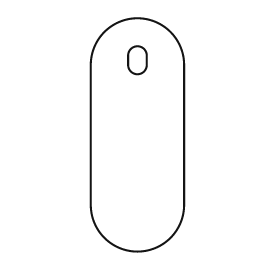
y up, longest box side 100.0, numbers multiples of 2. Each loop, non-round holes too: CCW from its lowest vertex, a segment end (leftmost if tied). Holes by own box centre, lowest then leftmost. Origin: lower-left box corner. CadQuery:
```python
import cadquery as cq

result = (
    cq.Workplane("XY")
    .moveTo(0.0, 20.0)
    .threePointArc((20.0, 0.0), (40.0, 20.0))
    .lineTo(40.0, 80.0)
    .threePointArc((20.0, 100.0), (0.0, 80.0))
    .close()
    .moveTo(16.0, 80.0)
    .threePointArc((20.0, 76.0), (24.0, 80.0))
    .lineTo(24.0, 84.0)
    .threePointArc((20.0, 88.0), (16.0, 84.0))
    .close()
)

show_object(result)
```